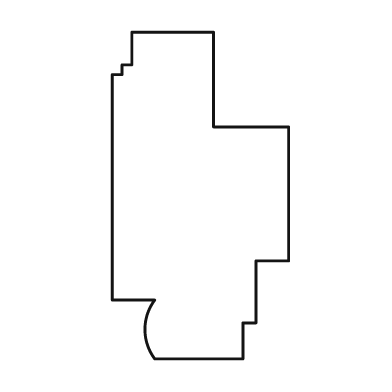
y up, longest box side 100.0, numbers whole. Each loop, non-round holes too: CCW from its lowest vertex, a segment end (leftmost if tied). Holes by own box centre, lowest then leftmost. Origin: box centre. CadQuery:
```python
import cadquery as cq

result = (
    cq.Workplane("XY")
    .moveTo(-14.0, -50.0)
    .lineTo(13.0, -50.0)
    .lineTo(13.0, -39.0)
    .lineTo(17.0, -39.0)
    .lineTo(17.0, -20.0)
    .lineTo(27.0, -20.0)
    .lineTo(27.0, 21.0)
    .lineTo(4.0, 21.0)
    .lineTo(4.0, 50.0)
    .lineTo(-21.0, 50.0)
    .lineTo(-21.0, 40.0)
    .lineTo(-24.0, 40.0)
    .lineTo(-24.0, 37.0)
    .lineTo(-27.0, 37.0)
    .lineTo(-27.0, -32.0)
    .lineTo(-14.0, -32.0)
    .threePointArc((-17.0, -41.0), (-14.0, -50.0))
    .close()
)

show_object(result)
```